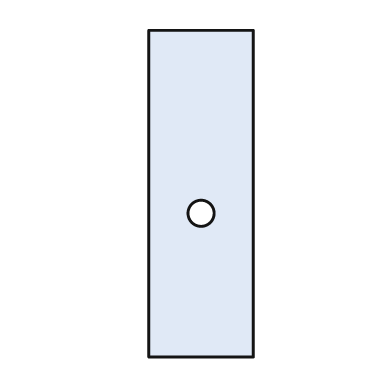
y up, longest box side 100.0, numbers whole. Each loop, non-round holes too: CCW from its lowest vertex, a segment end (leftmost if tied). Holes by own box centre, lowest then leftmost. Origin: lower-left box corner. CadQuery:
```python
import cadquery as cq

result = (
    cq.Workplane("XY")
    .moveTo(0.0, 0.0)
    .lineTo(32.0, 0.0)
    .lineTo(32.0, 100.0)
    .lineTo(0.0, 100.0)
    .close()
    .moveTo(16.0, 44.0)
    .circle(4.0)
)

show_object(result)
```